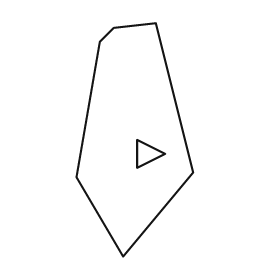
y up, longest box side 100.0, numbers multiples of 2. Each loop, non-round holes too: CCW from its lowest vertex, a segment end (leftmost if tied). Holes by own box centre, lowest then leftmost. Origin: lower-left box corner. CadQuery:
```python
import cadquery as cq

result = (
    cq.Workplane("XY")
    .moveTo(20.0, 0.0)
    .lineTo(50.0, 36.0)
    .lineTo(34.0, 100.0)
    .lineTo(16.0, 98.0)
    .lineTo(10.0, 92.0)
    .lineTo(0.0, 34.0)
    .close()
    .moveTo(26.0, 38.0)
    .lineTo(38.0, 44.0)
    .lineTo(26.0, 50.0)
    .close()
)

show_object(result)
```